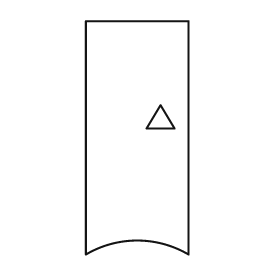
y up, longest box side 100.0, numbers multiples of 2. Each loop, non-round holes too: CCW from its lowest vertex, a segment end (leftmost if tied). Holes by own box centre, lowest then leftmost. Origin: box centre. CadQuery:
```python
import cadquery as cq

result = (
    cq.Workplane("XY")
    .moveTo(-22.0, -50.0)
    .threePointArc((0.0, -44.0), (22.0, -50.0))
    .lineTo(22.0, 50.0)
    .lineTo(-22.0, 50.0)
    .close()
    .moveTo(4.0, 4.0)
    .lineTo(16.0, 4.0)
    .lineTo(10.0, 14.0)
    .close()
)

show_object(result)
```